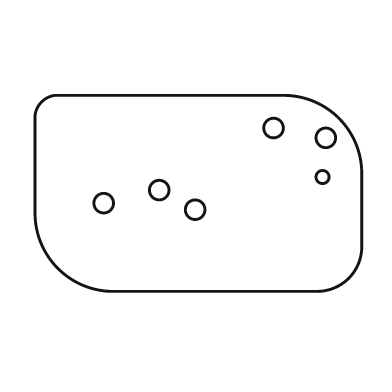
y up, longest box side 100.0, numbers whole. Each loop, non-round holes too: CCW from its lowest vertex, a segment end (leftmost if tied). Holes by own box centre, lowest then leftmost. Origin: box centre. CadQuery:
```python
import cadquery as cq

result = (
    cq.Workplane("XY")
    .moveTo(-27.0, -30.0)
    .lineTo(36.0, -30.0)
    .threePointArc((46.0, -26.0), (50.0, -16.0))
    .lineTo(50.0, 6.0)
    .threePointArc((43.0, 23.0), (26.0, 30.0))
    .lineTo(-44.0, 30.0)
    .threePointArc((-48.0, 28.0), (-50.0, 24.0))
    .lineTo(-50.0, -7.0)
    .threePointArc((-43.0, -23.0), (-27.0, -30.0))
    .close()
    .moveTo(-1.0, -5.0)
    .circle(3.0)
    .moveTo(-29.0, -3.0)
    .circle(3.0)
    .moveTo(-12.0, 1.0)
    .circle(3.0)
    .moveTo(38.0, 5.0)
    .circle(2.0)
    .moveTo(39.0, 17.0)
    .circle(3.0)
    .moveTo(23.0, 20.0)
    .circle(3.0)
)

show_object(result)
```